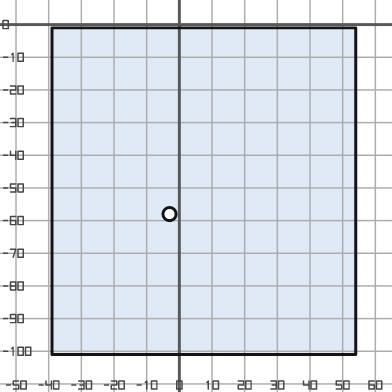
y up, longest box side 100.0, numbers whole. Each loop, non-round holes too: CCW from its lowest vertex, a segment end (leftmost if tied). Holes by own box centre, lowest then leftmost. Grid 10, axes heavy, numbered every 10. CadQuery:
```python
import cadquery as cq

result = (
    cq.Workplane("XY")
    .moveTo(-39.0, -101.0)
    .lineTo(54.0, -101.0)
    .lineTo(54.0, -1.0)
    .lineTo(-39.0, -1.0)
    .close()
    .moveTo(-3.0, -58.0)
    .circle(2.0)
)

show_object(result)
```